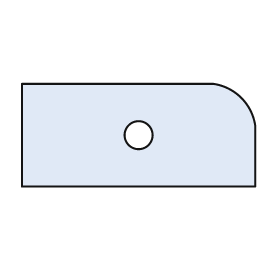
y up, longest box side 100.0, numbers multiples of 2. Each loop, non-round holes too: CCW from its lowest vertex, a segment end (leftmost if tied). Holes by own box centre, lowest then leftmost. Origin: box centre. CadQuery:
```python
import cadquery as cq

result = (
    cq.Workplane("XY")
    .moveTo(-50.0, -22.0)
    .lineTo(50.0, -22.0)
    .lineTo(50.0, 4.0)
    .threePointArc((44.0, 16.0), (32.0, 22.0))
    .lineTo(-50.0, 22.0)
    .close()
    .moveTo(0.0, 0.0)
    .circle(6.0)
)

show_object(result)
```